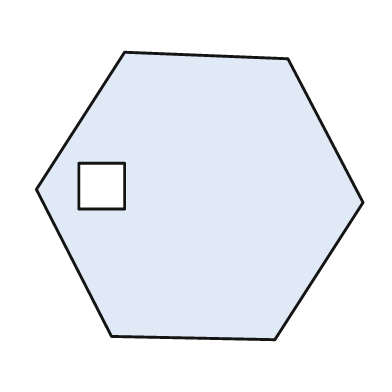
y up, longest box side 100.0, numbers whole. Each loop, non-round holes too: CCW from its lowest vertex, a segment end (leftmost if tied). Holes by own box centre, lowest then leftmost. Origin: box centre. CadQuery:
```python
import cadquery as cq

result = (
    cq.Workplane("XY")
    .moveTo(23.0, -44.0)
    .lineTo(50.0, -2.0)
    .lineTo(27.0, 42.0)
    .lineTo(-23.0, 44.0)
    .lineTo(-50.0, 2.0)
    .lineTo(-27.0, -43.0)
    .close()
    .moveTo(-37.0, -4.0)
    .lineTo(-23.0, -4.0)
    .lineTo(-23.0, 10.0)
    .lineTo(-37.0, 10.0)
    .close()
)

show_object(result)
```